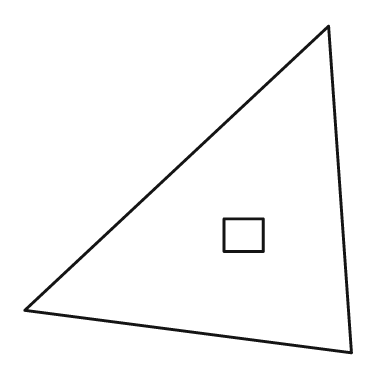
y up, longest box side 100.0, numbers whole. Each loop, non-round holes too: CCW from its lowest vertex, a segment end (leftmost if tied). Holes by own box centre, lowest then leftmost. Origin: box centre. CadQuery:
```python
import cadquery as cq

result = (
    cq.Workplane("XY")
    .moveTo(50.0, -50.0)
    .lineTo(43.0, 50.0)
    .lineTo(-50.0, -37.0)
    .close()
    .moveTo(11.0, -19.0)
    .lineTo(23.0, -19.0)
    .lineTo(23.0, -9.0)
    .lineTo(11.0, -9.0)
    .close()
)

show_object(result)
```